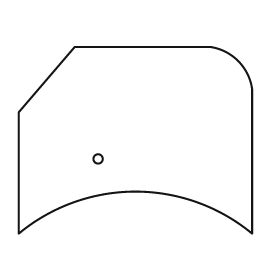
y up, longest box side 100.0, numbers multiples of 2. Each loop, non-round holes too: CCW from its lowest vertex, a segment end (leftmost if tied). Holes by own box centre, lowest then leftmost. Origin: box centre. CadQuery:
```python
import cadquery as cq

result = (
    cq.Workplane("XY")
    .moveTo(-50.0, -40.0)
    .threePointArc((0.0, -22.0), (50.0, -40.0))
    .lineTo(50.0, 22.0)
    .threePointArc((44.0, 34.0), (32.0, 40.0))
    .lineTo(-26.0, 40.0)
    .lineTo(-50.0, 12.0)
    .close()
    .moveTo(-16.0, -8.0)
    .circle(2.0)
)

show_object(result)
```